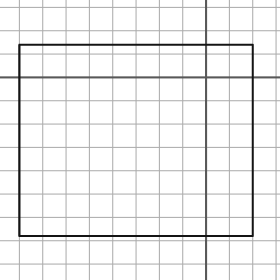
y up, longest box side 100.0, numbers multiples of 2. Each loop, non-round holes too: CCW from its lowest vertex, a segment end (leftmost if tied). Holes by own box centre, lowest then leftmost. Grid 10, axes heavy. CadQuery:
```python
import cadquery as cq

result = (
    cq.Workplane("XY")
    .moveTo(-80.0, -68.0)
    .lineTo(20.0, -68.0)
    .lineTo(20.0, 14.0)
    .lineTo(-80.0, 14.0)
    .close()
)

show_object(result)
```